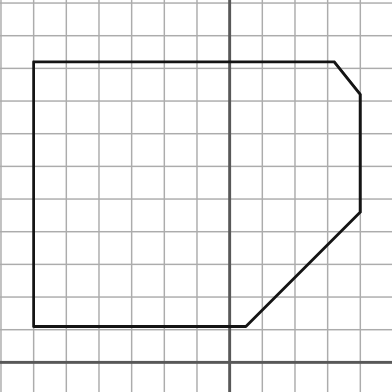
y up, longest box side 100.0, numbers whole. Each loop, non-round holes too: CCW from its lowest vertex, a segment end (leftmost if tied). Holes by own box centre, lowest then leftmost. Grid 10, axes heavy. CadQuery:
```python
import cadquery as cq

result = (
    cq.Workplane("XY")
    .moveTo(-60.0, 11.0)
    .lineTo(5.0, 11.0)
    .lineTo(40.0, 46.0)
    .lineTo(40.0, 82.0)
    .lineTo(32.0, 92.0)
    .lineTo(-60.0, 92.0)
    .close()
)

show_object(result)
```